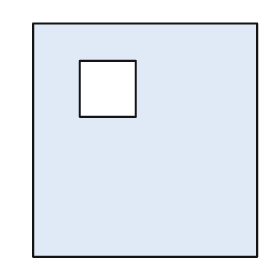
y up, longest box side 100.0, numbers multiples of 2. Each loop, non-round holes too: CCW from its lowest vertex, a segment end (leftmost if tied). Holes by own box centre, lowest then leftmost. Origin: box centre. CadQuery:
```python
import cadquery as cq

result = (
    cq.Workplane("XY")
    .moveTo(-48.0, -50.0)
    .lineTo(48.0, -50.0)
    .lineTo(48.0, 50.0)
    .lineTo(-48.0, 50.0)
    .close()
    .moveTo(-28.0, 10.0)
    .lineTo(-4.0, 10.0)
    .lineTo(-4.0, 34.0)
    .lineTo(-28.0, 34.0)
    .close()
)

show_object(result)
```